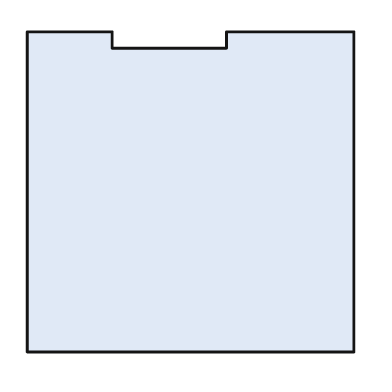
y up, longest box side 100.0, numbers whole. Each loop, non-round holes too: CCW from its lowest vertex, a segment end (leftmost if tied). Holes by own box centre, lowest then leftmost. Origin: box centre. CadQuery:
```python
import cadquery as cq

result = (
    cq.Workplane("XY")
    .moveTo(-50.0, -49.0)
    .lineTo(50.0, -49.0)
    .lineTo(50.0, 49.0)
    .lineTo(11.0, 49.0)
    .lineTo(11.0, 44.0)
    .lineTo(-24.0, 44.0)
    .lineTo(-24.0, 49.0)
    .lineTo(-50.0, 49.0)
    .close()
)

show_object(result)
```